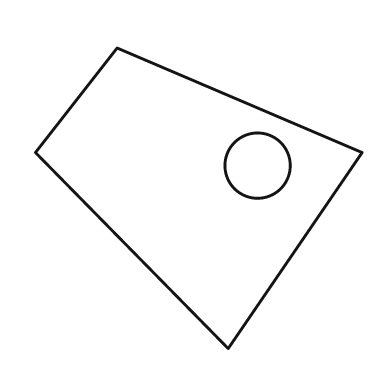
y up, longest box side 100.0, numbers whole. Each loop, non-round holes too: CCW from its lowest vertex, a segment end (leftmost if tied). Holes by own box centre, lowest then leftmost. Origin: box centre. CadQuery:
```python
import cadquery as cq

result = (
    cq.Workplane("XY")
    .moveTo(9.0, -46.0)
    .lineTo(50.0, 14.0)
    .lineTo(-25.0, 46.0)
    .lineTo(-50.0, 14.0)
    .close()
    .moveTo(18.0, 10.0)
    .circle(10.0)
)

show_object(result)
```